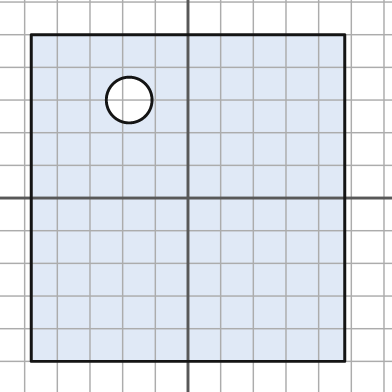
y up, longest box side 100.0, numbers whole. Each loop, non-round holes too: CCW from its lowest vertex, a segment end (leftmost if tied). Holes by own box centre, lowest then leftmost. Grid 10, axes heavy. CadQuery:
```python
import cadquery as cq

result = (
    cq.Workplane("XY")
    .moveTo(-48.0, -50.0)
    .lineTo(48.0, -50.0)
    .lineTo(48.0, 50.0)
    .lineTo(-48.0, 50.0)
    .close()
    .moveTo(-18.0, 30.0)
    .circle(7.0)
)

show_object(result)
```